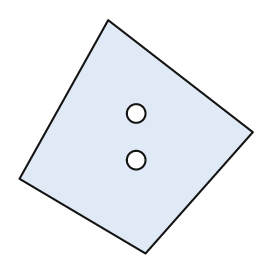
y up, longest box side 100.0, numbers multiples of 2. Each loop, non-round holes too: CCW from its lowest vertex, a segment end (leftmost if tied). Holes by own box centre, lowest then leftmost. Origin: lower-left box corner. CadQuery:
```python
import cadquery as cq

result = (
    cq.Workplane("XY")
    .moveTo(54.0, 0.0)
    .lineTo(100.0, 52.0)
    .lineTo(38.0, 100.0)
    .lineTo(0.0, 32.0)
    .close()
    .moveTo(50.0, 40.0)
    .circle(4.0)
    .moveTo(50.0, 60.0)
    .circle(4.0)
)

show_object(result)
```